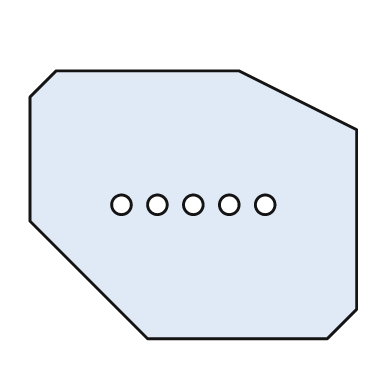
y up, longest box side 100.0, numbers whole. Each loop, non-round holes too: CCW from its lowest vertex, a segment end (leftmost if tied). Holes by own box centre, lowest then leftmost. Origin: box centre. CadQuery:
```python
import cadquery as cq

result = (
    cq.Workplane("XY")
    .moveTo(-14.0, -41.0)
    .lineTo(41.0, -41.0)
    .lineTo(50.0, -32.0)
    .lineTo(50.0, 23.0)
    .lineTo(14.0, 41.0)
    .lineTo(-42.0, 41.0)
    .lineTo(-50.0, 33.0)
    .lineTo(-50.0, -5.0)
    .close()
    .moveTo(-22.0, 0.0)
    .circle(3.0)
    .moveTo(-11.0, 0.0)
    .circle(3.0)
    .moveTo(0.0, 0.0)
    .circle(3.0)
    .moveTo(11.0, 0.0)
    .circle(3.0)
    .moveTo(22.0, 0.0)
    .circle(3.0)
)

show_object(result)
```